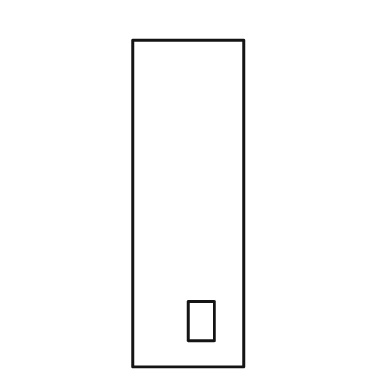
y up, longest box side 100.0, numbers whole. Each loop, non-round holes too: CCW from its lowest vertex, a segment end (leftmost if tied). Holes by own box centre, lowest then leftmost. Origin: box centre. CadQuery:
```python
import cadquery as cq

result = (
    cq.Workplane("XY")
    .moveTo(-17.0, -50.0)
    .lineTo(17.0, -50.0)
    .lineTo(17.0, 50.0)
    .lineTo(-17.0, 50.0)
    .close()
    .moveTo(0.0, -42.0)
    .lineTo(8.0, -42.0)
    .lineTo(8.0, -30.0)
    .lineTo(0.0, -30.0)
    .close()
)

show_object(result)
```